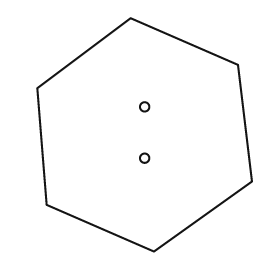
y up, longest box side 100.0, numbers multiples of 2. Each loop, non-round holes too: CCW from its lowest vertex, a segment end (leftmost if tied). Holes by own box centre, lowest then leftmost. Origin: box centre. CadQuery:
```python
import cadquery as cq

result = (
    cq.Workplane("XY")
    .moveTo(4.0, -50.0)
    .lineTo(46.0, -20.0)
    .lineTo(40.0, 30.0)
    .lineTo(-6.0, 50.0)
    .lineTo(-46.0, 20.0)
    .lineTo(-42.0, -30.0)
    .close()
    .moveTo(0.0, -10.0)
    .circle(2.0)
    .moveTo(0.0, 12.0)
    .circle(2.0)
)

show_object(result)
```